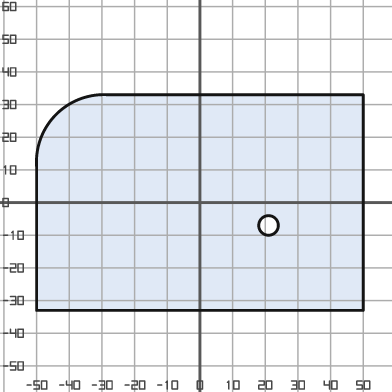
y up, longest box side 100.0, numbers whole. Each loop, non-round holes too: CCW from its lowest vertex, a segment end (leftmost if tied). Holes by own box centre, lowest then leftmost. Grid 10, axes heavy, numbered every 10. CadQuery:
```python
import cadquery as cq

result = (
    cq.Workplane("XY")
    .moveTo(-50.0, -33.0)
    .lineTo(50.0, -33.0)
    .lineTo(50.0, 33.0)
    .lineTo(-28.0, 33.0)
    .threePointArc((-44.0, 27.0), (-50.0, 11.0))
    .close()
    .moveTo(21.0, -7.0)
    .circle(3.0)
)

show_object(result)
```